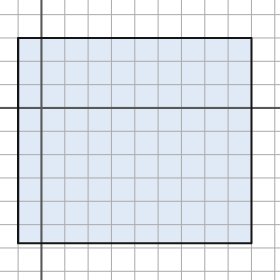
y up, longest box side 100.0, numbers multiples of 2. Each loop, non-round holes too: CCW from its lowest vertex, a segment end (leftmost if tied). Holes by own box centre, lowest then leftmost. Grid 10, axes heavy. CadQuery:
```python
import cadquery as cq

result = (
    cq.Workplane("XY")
    .moveTo(-10.0, -58.0)
    .lineTo(90.0, -58.0)
    .lineTo(90.0, 30.0)
    .lineTo(-10.0, 30.0)
    .close()
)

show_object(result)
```